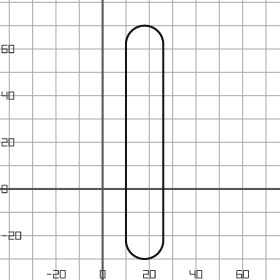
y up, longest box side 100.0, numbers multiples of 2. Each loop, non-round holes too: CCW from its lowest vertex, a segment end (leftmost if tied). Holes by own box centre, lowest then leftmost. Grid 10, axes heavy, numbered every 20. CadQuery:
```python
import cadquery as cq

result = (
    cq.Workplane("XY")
    .moveTo(10.0, -22.0)
    .threePointArc((18.0, -30.0), (26.0, -22.0))
    .lineTo(26.0, 62.0)
    .threePointArc((18.0, 70.0), (10.0, 62.0))
    .close()
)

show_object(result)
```